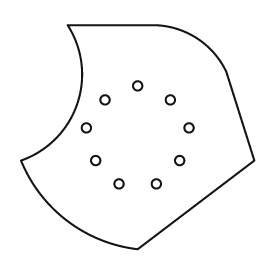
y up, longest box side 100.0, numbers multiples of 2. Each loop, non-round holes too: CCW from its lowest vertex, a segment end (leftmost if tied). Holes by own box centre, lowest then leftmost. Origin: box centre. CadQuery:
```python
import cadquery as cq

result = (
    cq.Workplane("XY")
    .moveTo(0.0, -48.0)
    .lineTo(50.0, -10.0)
    .lineTo(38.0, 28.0)
    .threePointArc((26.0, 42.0), (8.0, 48.0))
    .lineTo(-30.0, 48.0)
    .threePointArc((-26.0, 14.0), (-50.0, -10.0))
    .threePointArc((-30.0, -36.0), (0.0, -48.0))
    .close()
    .moveTo(-8.0, -20.0)
    .circle(2.0)
    .moveTo(8.0, -20.0)
    .circle(2.0)
    .moveTo(-18.0, -10.0)
    .circle(2.0)
    .moveTo(18.0, -10.0)
    .circle(2.0)
    .moveTo(-22.0, 4.0)
    .circle(2.0)
    .moveTo(22.0, 4.0)
    .circle(2.0)
    .moveTo(-14.0, 16.0)
    .circle(2.0)
    .moveTo(14.0, 16.0)
    .circle(2.0)
    .moveTo(0.0, 22.0)
    .circle(2.0)
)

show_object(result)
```